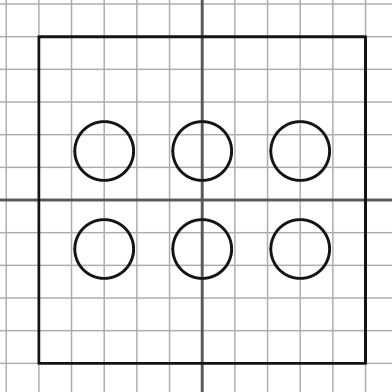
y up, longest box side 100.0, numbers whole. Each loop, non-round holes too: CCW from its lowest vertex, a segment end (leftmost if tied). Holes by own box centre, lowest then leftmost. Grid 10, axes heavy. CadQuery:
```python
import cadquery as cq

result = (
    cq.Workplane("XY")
    .moveTo(-50.0, -50.0)
    .lineTo(50.0, -50.0)
    .lineTo(50.0, 50.0)
    .lineTo(-50.0, 50.0)
    .close()
    .moveTo(-30.0, -15.0)
    .circle(9.0)
    .moveTo(0.0, -15.0)
    .circle(9.0)
    .moveTo(30.0, -15.0)
    .circle(9.0)
    .moveTo(-30.0, 15.0)
    .circle(9.0)
    .moveTo(0.0, 15.0)
    .circle(9.0)
    .moveTo(30.0, 15.0)
    .circle(9.0)
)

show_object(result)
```